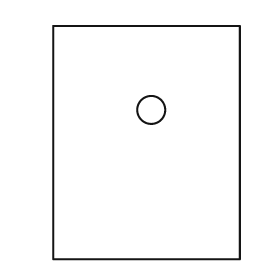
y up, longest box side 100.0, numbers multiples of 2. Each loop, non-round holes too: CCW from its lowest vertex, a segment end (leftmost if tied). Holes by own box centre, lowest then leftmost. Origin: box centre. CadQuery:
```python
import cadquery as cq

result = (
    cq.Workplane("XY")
    .moveTo(-40.0, -50.0)
    .lineTo(40.0, -50.0)
    .lineTo(40.0, 50.0)
    .lineTo(-40.0, 50.0)
    .close()
    .moveTo(2.0, 14.0)
    .circle(6.0)
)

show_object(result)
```